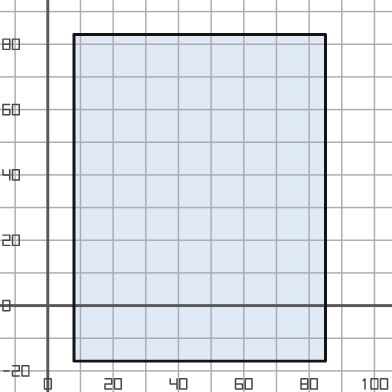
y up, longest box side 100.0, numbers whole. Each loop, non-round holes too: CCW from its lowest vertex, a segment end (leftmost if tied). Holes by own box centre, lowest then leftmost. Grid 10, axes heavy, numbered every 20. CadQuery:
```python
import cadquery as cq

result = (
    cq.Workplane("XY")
    .moveTo(8.0, -17.0)
    .lineTo(85.0, -17.0)
    .lineTo(85.0, 83.0)
    .lineTo(8.0, 83.0)
    .close()
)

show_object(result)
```